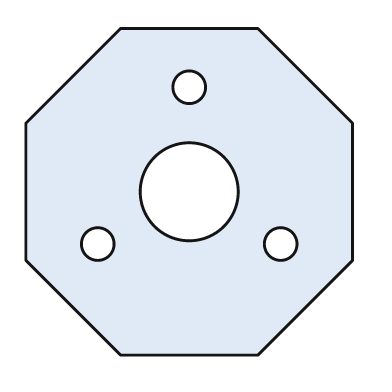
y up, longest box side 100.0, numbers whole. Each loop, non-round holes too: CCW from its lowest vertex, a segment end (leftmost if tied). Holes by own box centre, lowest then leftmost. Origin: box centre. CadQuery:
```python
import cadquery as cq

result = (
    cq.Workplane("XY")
    .moveTo(-21.0, -50.0)
    .lineTo(21.0, -50.0)
    .lineTo(50.0, -21.0)
    .lineTo(50.0, 21.0)
    .lineTo(21.0, 50.0)
    .lineTo(-21.0, 50.0)
    .lineTo(-50.0, 21.0)
    .lineTo(-50.0, -21.0)
    .close()
    .moveTo(-28.0, -16.0)
    .circle(5.0)
    .moveTo(28.0, -16.0)
    .circle(5.0)
    .moveTo(0.0, 0.0)
    .circle(15.0)
    .moveTo(0.0, 32.0)
    .circle(5.0)
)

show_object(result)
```